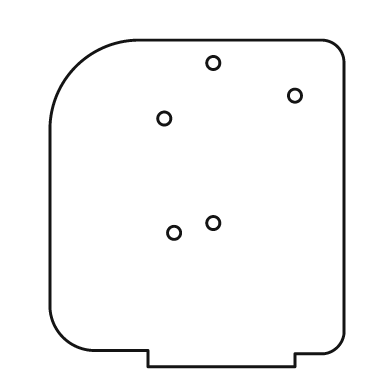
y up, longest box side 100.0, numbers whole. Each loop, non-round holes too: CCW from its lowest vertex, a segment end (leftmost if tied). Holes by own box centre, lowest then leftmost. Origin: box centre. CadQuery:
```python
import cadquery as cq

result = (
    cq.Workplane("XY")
    .moveTo(-15.0, -50.0)
    .lineTo(30.0, -50.0)
    .lineTo(30.0, -46.0)
    .lineTo(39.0, -46.0)
    .threePointArc((43.0, -44.0), (45.0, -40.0))
    .lineTo(45.0, 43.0)
    .threePointArc((43.0, 48.0), (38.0, 50.0))
    .lineTo(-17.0, 50.0)
    .threePointArc((-37.0, 42.0), (-45.0, 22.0))
    .lineTo(-45.0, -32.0)
    .threePointArc((-41.0, -41.0), (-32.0, -45.0))
    .lineTo(-15.0, -45.0)
    .close()
    .moveTo(-7.0, -9.0)
    .circle(2.0)
    .moveTo(5.0, -6.0)
    .circle(2.0)
    .moveTo(-10.0, 26.0)
    .circle(2.0)
    .moveTo(30.0, 33.0)
    .circle(2.0)
    .moveTo(5.0, 43.0)
    .circle(2.0)
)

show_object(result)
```